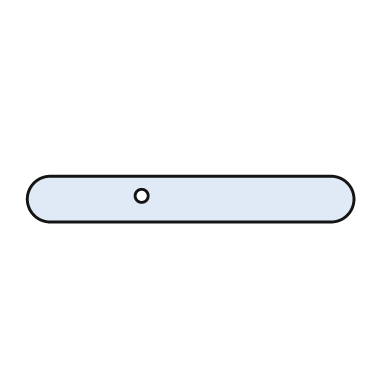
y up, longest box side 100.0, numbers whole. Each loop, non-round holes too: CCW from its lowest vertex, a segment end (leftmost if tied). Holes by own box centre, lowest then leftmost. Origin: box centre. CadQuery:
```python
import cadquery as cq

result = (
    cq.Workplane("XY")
    .moveTo(-43.0, -7.0)
    .lineTo(43.0, -7.0)
    .threePointArc((50.0, 0.0), (43.0, 7.0))
    .lineTo(-43.0, 7.0)
    .threePointArc((-50.0, 0.0), (-43.0, -7.0))
    .close()
    .moveTo(-15.0, 1.0)
    .circle(2.0)
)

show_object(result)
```